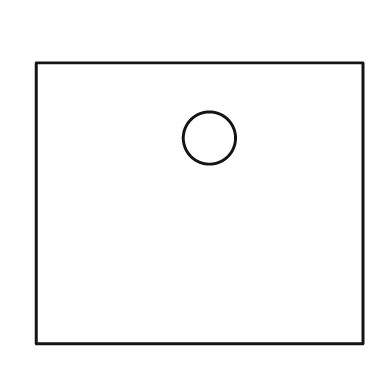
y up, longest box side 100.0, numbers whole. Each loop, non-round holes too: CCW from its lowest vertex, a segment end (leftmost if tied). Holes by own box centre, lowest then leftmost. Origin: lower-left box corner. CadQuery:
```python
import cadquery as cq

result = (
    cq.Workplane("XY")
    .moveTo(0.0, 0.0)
    .lineTo(100.0, 0.0)
    .lineTo(100.0, 86.0)
    .lineTo(0.0, 86.0)
    .close()
    .moveTo(53.0, 63.0)
    .circle(8.0)
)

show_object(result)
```